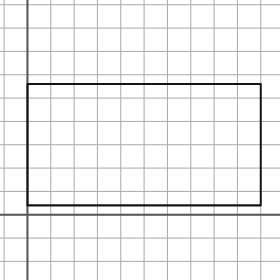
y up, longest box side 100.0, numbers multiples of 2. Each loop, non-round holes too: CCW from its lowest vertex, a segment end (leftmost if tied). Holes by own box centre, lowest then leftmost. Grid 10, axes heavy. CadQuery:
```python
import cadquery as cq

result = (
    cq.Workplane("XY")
    .moveTo(0.0, 4.0)
    .lineTo(100.0, 4.0)
    .lineTo(100.0, 56.0)
    .lineTo(0.0, 56.0)
    .close()
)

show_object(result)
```